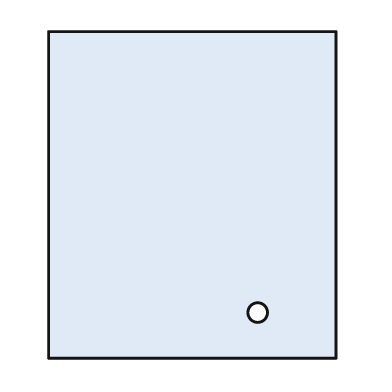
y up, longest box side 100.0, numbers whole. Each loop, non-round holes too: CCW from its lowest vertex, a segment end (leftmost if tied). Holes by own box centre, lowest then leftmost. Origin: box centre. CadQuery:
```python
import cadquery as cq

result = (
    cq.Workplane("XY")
    .moveTo(-44.0, -50.0)
    .lineTo(44.0, -50.0)
    .lineTo(44.0, 50.0)
    .lineTo(-44.0, 50.0)
    .close()
    .moveTo(20.0, -36.0)
    .circle(3.0)
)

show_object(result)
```